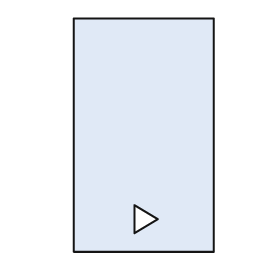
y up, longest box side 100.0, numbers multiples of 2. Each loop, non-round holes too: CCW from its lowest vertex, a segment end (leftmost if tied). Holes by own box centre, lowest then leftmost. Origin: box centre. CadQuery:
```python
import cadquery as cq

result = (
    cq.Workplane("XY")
    .moveTo(-30.0, -50.0)
    .lineTo(30.0, -50.0)
    .lineTo(30.0, 50.0)
    .lineTo(-30.0, 50.0)
    .close()
    .moveTo(-4.0, -42.0)
    .lineTo(6.0, -36.0)
    .lineTo(-4.0, -30.0)
    .close()
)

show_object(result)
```